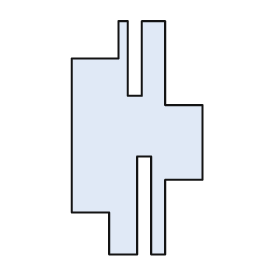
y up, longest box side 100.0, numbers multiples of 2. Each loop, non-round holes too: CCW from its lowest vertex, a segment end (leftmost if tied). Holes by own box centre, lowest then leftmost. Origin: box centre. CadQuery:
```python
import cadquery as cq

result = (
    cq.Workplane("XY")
    .moveTo(-12.0, -50.0)
    .lineTo(0.0, -50.0)
    .lineTo(0.0, -8.0)
    .lineTo(6.0, -8.0)
    .lineTo(6.0, -50.0)
    .lineTo(12.0, -50.0)
    .lineTo(12.0, -18.0)
    .lineTo(28.0, -18.0)
    .lineTo(28.0, 14.0)
    .lineTo(12.0, 14.0)
    .lineTo(12.0, 50.0)
    .lineTo(2.0, 50.0)
    .lineTo(2.0, 18.0)
    .lineTo(-4.0, 18.0)
    .lineTo(-4.0, 50.0)
    .lineTo(-8.0, 50.0)
    .lineTo(-8.0, 34.0)
    .lineTo(-28.0, 34.0)
    .lineTo(-28.0, -32.0)
    .lineTo(-12.0, -32.0)
    .close()
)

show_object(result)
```